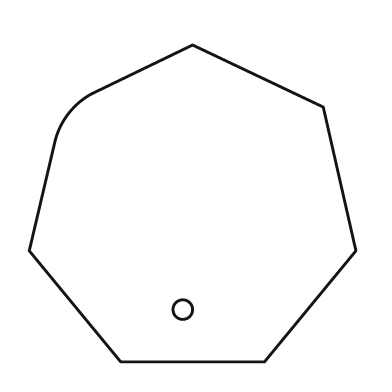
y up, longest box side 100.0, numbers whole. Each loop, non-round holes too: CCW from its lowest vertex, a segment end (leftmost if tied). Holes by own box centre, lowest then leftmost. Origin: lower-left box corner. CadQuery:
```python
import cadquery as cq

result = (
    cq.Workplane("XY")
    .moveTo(28.0, 0.0)
    .lineTo(72.0, 0.0)
    .lineTo(100.0, 34.0)
    .lineTo(90.0, 78.0)
    .lineTo(50.0, 97.0)
    .lineTo(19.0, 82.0)
    .threePointArc((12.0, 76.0), (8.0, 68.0))
    .lineTo(0.0, 34.0)
    .close()
    .moveTo(47.0, 16.0)
    .circle(3.0)
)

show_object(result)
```